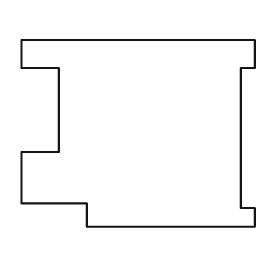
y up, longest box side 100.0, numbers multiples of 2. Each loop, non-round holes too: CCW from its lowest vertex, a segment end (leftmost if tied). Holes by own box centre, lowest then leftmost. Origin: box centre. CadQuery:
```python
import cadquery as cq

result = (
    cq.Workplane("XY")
    .moveTo(-22.0, -40.0)
    .lineTo(50.0, -40.0)
    .lineTo(50.0, -32.0)
    .lineTo(44.0, -32.0)
    .lineTo(44.0, 28.0)
    .lineTo(50.0, 28.0)
    .lineTo(50.0, 40.0)
    .lineTo(-50.0, 40.0)
    .lineTo(-50.0, 28.0)
    .lineTo(-34.0, 28.0)
    .lineTo(-34.0, -8.0)
    .lineTo(-50.0, -8.0)
    .lineTo(-50.0, -30.0)
    .lineTo(-22.0, -30.0)
    .close()
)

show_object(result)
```